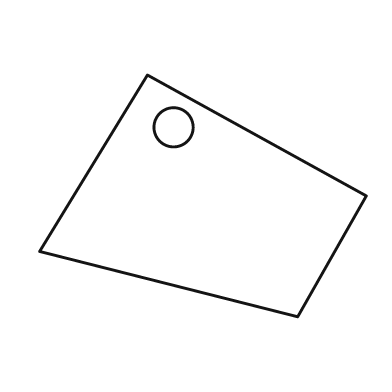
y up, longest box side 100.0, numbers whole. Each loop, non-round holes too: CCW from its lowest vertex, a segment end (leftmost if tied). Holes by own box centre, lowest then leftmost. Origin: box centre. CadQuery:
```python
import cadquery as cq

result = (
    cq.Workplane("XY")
    .moveTo(29.0, -37.0)
    .lineTo(50.0, 0.0)
    .lineTo(-17.0, 37.0)
    .lineTo(-50.0, -17.0)
    .close()
    .moveTo(-9.0, 21.0)
    .circle(6.0)
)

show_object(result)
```